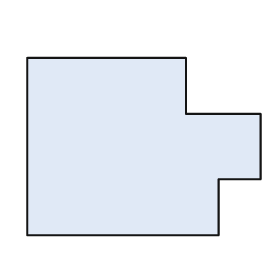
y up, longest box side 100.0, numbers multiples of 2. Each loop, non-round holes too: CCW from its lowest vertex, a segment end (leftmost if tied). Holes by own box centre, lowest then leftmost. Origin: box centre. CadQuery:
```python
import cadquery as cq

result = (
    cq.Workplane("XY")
    .moveTo(-50.0, -38.0)
    .lineTo(32.0, -38.0)
    .lineTo(32.0, -14.0)
    .lineTo(50.0, -14.0)
    .lineTo(50.0, 14.0)
    .lineTo(18.0, 14.0)
    .lineTo(18.0, 38.0)
    .lineTo(-50.0, 38.0)
    .close()
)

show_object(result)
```